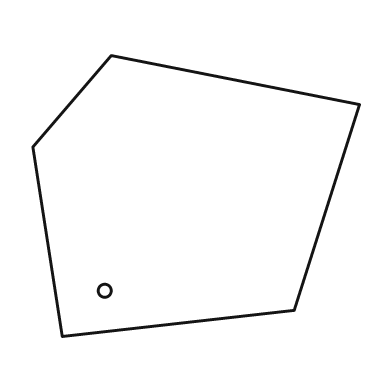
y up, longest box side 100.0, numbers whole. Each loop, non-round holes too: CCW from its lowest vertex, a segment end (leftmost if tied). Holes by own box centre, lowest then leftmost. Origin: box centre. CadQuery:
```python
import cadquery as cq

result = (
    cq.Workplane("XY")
    .moveTo(-41.0, -43.0)
    .lineTo(30.0, -35.0)
    .lineTo(50.0, 28.0)
    .lineTo(-26.0, 43.0)
    .lineTo(-50.0, 15.0)
    .close()
    .moveTo(-28.0, -29.0)
    .circle(2.0)
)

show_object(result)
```